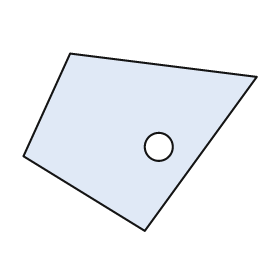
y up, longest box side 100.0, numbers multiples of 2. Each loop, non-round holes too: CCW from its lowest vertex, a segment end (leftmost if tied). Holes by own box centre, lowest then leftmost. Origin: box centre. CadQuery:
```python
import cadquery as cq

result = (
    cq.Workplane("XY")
    .moveTo(2.0, -38.0)
    .lineTo(50.0, 28.0)
    .lineTo(-30.0, 38.0)
    .lineTo(-50.0, -6.0)
    .close()
    .moveTo(8.0, -2.0)
    .circle(6.0)
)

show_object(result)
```